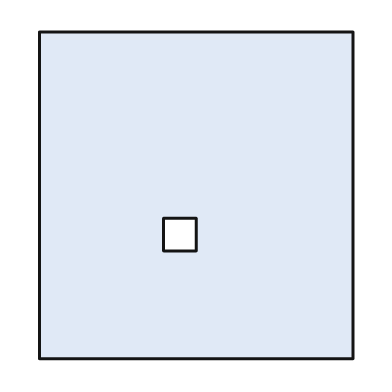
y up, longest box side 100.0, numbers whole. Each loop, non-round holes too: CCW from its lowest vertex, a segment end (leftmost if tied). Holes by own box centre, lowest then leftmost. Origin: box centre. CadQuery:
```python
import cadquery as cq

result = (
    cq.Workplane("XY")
    .moveTo(-48.0, -50.0)
    .lineTo(48.0, -50.0)
    .lineTo(48.0, 50.0)
    .lineTo(-48.0, 50.0)
    .close()
    .moveTo(-10.0, -17.0)
    .lineTo(0.0, -17.0)
    .lineTo(0.0, -7.0)
    .lineTo(-10.0, -7.0)
    .close()
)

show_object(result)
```